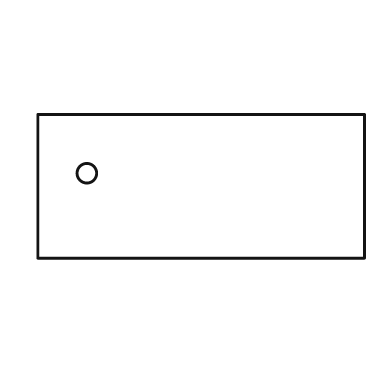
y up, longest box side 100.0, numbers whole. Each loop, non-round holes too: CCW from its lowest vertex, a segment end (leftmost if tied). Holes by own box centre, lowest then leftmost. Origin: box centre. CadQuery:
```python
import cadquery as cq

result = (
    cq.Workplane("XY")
    .moveTo(-50.0, -22.0)
    .lineTo(50.0, -22.0)
    .lineTo(50.0, 22.0)
    .lineTo(-50.0, 22.0)
    .close()
    .moveTo(-35.0, 4.0)
    .circle(3.0)
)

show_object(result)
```